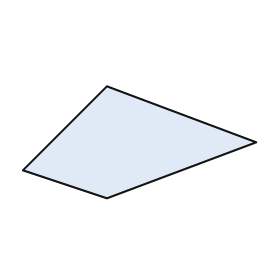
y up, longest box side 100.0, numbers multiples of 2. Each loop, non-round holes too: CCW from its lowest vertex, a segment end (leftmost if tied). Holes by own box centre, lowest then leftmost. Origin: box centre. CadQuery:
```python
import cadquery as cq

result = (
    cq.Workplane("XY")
    .moveTo(-14.0, -24.0)
    .lineTo(50.0, 0.0)
    .lineTo(-14.0, 24.0)
    .lineTo(-50.0, -12.0)
    .close()
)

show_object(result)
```